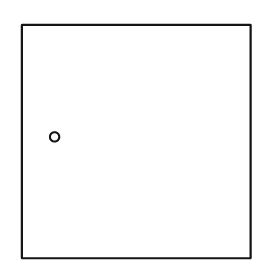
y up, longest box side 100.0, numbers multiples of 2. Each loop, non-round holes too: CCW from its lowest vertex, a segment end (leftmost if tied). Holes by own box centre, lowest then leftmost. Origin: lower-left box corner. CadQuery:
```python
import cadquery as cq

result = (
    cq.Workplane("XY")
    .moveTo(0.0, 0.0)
    .lineTo(98.0, 0.0)
    .lineTo(98.0, 100.0)
    .lineTo(0.0, 100.0)
    .close()
    .moveTo(14.0, 52.0)
    .circle(2.0)
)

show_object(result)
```